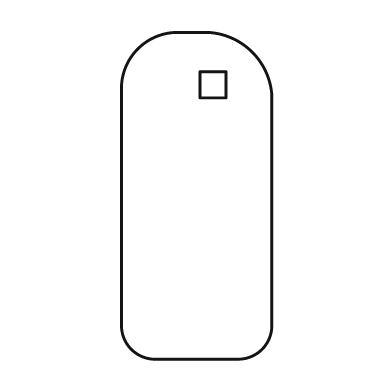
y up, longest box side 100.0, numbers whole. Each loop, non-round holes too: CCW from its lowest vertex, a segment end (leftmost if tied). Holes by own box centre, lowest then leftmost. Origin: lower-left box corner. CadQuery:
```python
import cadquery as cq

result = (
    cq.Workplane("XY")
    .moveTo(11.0, 0.0)
    .lineTo(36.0, 0.0)
    .threePointArc((43.0, 3.0), (46.0, 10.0))
    .lineTo(46.0, 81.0)
    .threePointArc((40.0, 94.0), (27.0, 100.0))
    .lineTo(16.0, 100.0)
    .threePointArc((5.0, 95.0), (0.0, 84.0))
    .lineTo(0.0, 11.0)
    .threePointArc((3.0, 3.0), (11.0, 0.0))
    .close()
    .moveTo(24.0, 80.0)
    .lineTo(32.0, 80.0)
    .lineTo(32.0, 88.0)
    .lineTo(24.0, 88.0)
    .close()
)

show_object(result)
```